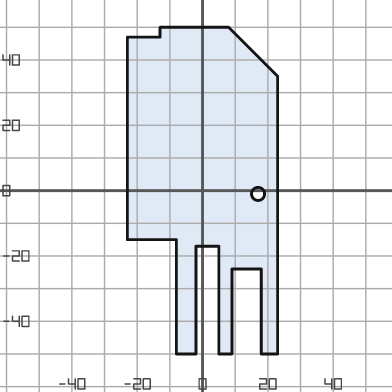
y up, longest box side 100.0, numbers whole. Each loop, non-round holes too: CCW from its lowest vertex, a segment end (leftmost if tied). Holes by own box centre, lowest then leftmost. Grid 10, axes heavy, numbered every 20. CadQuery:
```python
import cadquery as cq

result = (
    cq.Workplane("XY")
    .moveTo(-8.0, -50.0)
    .lineTo(-2.0, -50.0)
    .lineTo(-2.0, -17.0)
    .lineTo(5.0, -17.0)
    .lineTo(5.0, -50.0)
    .lineTo(9.0, -50.0)
    .lineTo(9.0, -24.0)
    .lineTo(18.0, -24.0)
    .lineTo(18.0, -50.0)
    .lineTo(23.0, -50.0)
    .lineTo(23.0, 35.0)
    .lineTo(8.0, 50.0)
    .lineTo(-13.0, 50.0)
    .lineTo(-13.0, 47.0)
    .lineTo(-23.0, 47.0)
    .lineTo(-23.0, -15.0)
    .lineTo(-8.0, -15.0)
    .close()
    .moveTo(17.0, -1.0)
    .circle(2.0)
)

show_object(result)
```